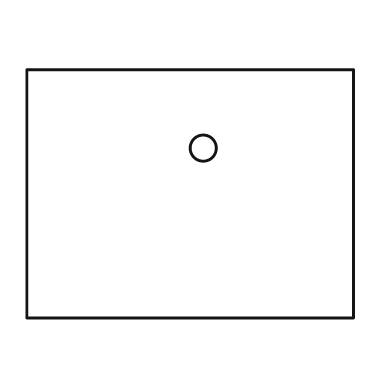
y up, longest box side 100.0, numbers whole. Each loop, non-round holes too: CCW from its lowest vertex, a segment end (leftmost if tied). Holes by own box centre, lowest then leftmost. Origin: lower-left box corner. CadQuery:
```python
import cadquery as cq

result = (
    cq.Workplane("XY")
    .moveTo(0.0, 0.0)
    .lineTo(100.0, 0.0)
    .lineTo(100.0, 76.0)
    .lineTo(0.0, 76.0)
    .close()
    .moveTo(54.0, 52.0)
    .circle(4.0)
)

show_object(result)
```